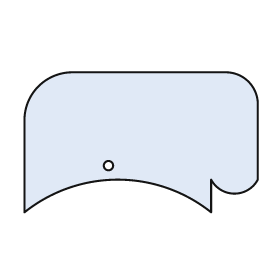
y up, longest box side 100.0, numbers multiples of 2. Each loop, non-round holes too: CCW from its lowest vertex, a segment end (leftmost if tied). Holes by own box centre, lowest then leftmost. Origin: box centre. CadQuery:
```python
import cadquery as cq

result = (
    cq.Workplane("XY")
    .moveTo(-50.0, -30.0)
    .threePointArc((-10.0, -16.0), (30.0, -30.0))
    .lineTo(30.0, -16.0)
    .threePointArc((40.0, -22.0), (50.0, -16.0))
    .lineTo(50.0, 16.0)
    .threePointArc((46.0, 26.0), (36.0, 30.0))
    .lineTo(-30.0, 30.0)
    .threePointArc((-44.0, 24.0), (-50.0, 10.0))
    .close()
    .moveTo(-14.0, -10.0)
    .circle(2.0)
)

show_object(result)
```